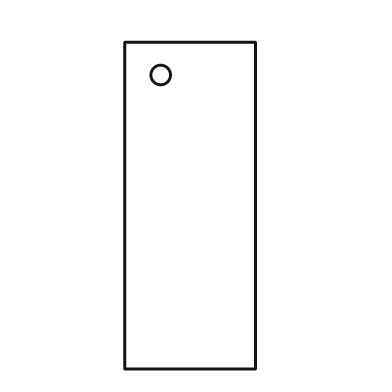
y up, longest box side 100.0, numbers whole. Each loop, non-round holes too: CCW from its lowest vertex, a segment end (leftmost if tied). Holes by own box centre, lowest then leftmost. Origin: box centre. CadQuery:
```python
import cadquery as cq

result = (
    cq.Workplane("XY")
    .moveTo(-20.0, -50.0)
    .lineTo(20.0, -50.0)
    .lineTo(20.0, 50.0)
    .lineTo(-20.0, 50.0)
    .close()
    .moveTo(-9.0, 40.0)
    .circle(3.0)
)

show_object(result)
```